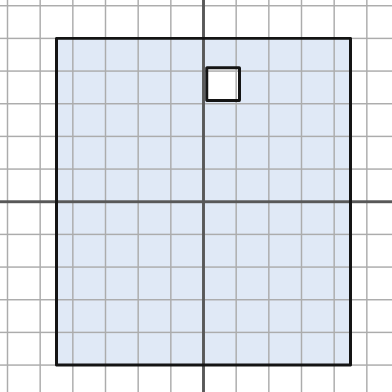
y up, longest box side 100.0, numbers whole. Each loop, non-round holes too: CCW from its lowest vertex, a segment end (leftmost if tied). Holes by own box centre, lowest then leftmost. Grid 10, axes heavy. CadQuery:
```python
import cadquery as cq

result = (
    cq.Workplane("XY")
    .moveTo(-45.0, -50.0)
    .lineTo(45.0, -50.0)
    .lineTo(45.0, 50.0)
    .lineTo(-45.0, 50.0)
    .close()
    .moveTo(1.0, 31.0)
    .lineTo(11.0, 31.0)
    .lineTo(11.0, 41.0)
    .lineTo(1.0, 41.0)
    .close()
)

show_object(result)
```